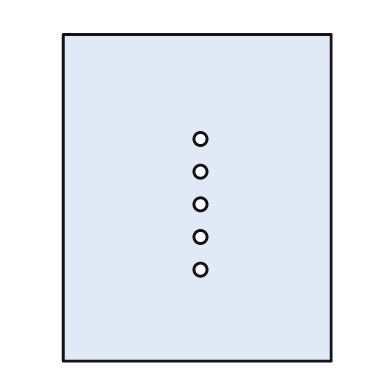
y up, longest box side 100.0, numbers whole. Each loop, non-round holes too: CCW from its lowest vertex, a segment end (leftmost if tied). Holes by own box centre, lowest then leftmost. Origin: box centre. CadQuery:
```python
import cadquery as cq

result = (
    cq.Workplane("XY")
    .moveTo(-41.0, -50.0)
    .lineTo(41.0, -50.0)
    .lineTo(41.0, 50.0)
    .lineTo(-41.0, 50.0)
    .close()
    .moveTo(1.0, -22.0)
    .circle(2.0)
    .moveTo(1.0, -12.0)
    .circle(2.0)
    .moveTo(1.0, -2.0)
    .circle(2.0)
    .moveTo(1.0, 8.0)
    .circle(2.0)
    .moveTo(1.0, 18.0)
    .circle(2.0)
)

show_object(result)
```